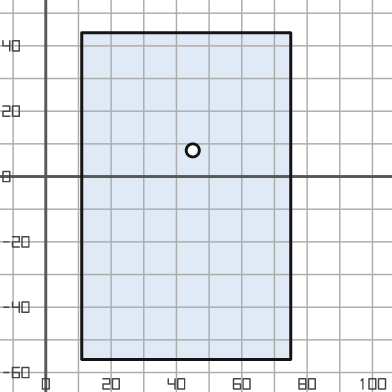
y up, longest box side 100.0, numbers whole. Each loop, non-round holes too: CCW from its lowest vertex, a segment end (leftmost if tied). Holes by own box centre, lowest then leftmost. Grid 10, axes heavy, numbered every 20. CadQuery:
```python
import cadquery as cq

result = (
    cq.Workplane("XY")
    .moveTo(11.0, -56.0)
    .lineTo(75.0, -56.0)
    .lineTo(75.0, 44.0)
    .lineTo(11.0, 44.0)
    .close()
    .moveTo(45.0, 8.0)
    .circle(2.0)
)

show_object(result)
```